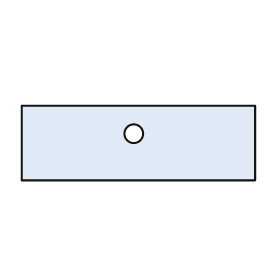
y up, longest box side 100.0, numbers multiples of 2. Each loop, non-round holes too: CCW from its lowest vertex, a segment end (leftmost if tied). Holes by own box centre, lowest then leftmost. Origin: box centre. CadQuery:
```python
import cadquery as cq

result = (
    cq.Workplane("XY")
    .moveTo(-50.0, -16.0)
    .lineTo(50.0, -16.0)
    .lineTo(50.0, 16.0)
    .lineTo(-50.0, 16.0)
    .close()
    .moveTo(-2.0, 4.0)
    .circle(4.0)
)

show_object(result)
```